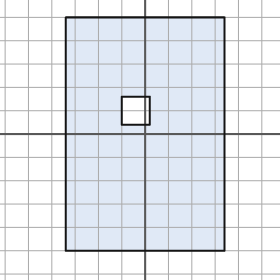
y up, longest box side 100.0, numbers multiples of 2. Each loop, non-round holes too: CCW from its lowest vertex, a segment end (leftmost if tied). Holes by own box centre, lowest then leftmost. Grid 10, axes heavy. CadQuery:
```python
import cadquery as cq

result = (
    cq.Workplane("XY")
    .moveTo(-34.0, -50.0)
    .lineTo(34.0, -50.0)
    .lineTo(34.0, 50.0)
    .lineTo(-34.0, 50.0)
    .close()
    .moveTo(-10.0, 4.0)
    .lineTo(2.0, 4.0)
    .lineTo(2.0, 16.0)
    .lineTo(-10.0, 16.0)
    .close()
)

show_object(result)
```